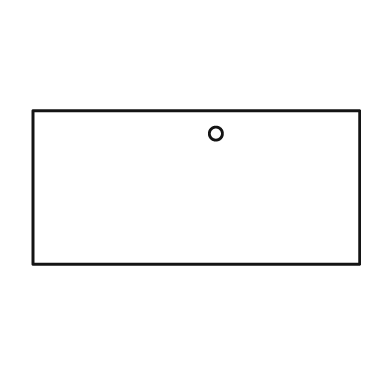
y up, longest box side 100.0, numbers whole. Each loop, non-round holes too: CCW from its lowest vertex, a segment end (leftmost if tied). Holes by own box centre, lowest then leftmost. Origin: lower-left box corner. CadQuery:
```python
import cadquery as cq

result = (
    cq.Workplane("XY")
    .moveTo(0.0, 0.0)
    .lineTo(100.0, 0.0)
    .lineTo(100.0, 47.0)
    .lineTo(0.0, 47.0)
    .close()
    .moveTo(56.0, 40.0)
    .circle(2.0)
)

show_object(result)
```